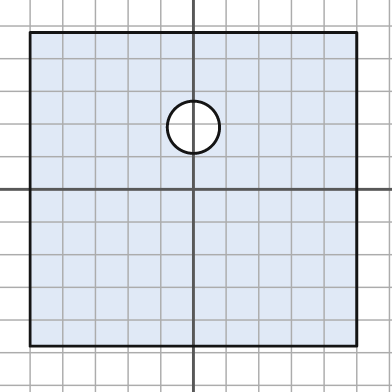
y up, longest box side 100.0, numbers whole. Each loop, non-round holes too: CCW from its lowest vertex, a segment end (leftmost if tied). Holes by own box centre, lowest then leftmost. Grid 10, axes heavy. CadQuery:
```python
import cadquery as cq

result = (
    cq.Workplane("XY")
    .moveTo(-50.0, -48.0)
    .lineTo(50.0, -48.0)
    .lineTo(50.0, 48.0)
    .lineTo(-50.0, 48.0)
    .close()
    .moveTo(0.0, 19.0)
    .circle(8.0)
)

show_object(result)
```